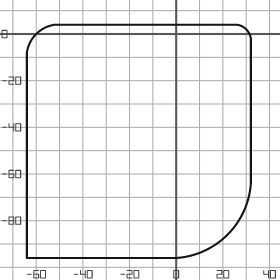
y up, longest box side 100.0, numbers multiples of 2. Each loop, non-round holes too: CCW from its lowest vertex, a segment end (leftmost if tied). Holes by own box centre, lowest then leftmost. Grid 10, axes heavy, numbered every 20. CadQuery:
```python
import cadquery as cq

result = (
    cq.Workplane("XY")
    .moveTo(-64.0, -96.0)
    .lineTo(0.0, -96.0)
    .threePointArc((22.0, -86.0), (32.0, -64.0))
    .lineTo(32.0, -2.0)
    .threePointArc((30.0, 2.0), (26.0, 4.0))
    .lineTo(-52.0, 4.0)
    .threePointArc((-60.0, 0.0), (-64.0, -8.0))
    .close()
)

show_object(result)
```